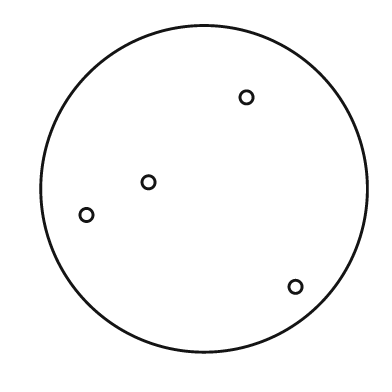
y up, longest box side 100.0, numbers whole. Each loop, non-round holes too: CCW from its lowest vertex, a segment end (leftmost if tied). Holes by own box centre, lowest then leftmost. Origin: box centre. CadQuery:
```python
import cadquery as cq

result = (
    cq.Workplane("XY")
    .moveTo(0.0, 0.0)
    .circle(50.0)
    .moveTo(28.0, -30.0)
    .circle(2.0)
    .moveTo(-36.0, -8.0)
    .circle(2.0)
    .moveTo(-17.0, 2.0)
    .circle(2.0)
    .moveTo(13.0, 28.0)
    .circle(2.0)
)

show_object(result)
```